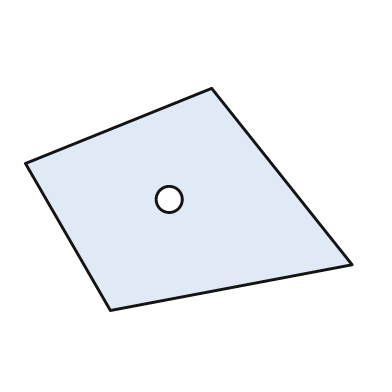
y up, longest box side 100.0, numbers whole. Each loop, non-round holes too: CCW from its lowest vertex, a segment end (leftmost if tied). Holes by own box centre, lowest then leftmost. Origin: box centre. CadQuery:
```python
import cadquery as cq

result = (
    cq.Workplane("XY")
    .moveTo(-24.0, -34.0)
    .lineTo(50.0, -20.0)
    .lineTo(7.0, 34.0)
    .lineTo(-50.0, 11.0)
    .close()
    .moveTo(-6.0, 0.0)
    .circle(4.0)
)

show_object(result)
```